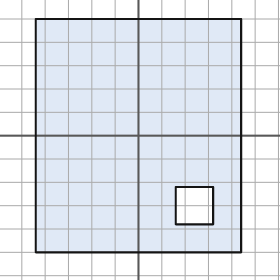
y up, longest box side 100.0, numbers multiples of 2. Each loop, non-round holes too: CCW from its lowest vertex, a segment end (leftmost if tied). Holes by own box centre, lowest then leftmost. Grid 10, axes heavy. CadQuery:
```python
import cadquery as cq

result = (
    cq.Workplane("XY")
    .moveTo(-44.0, -50.0)
    .lineTo(44.0, -50.0)
    .lineTo(44.0, 50.0)
    .lineTo(-44.0, 50.0)
    .close()
    .moveTo(16.0, -38.0)
    .lineTo(32.0, -38.0)
    .lineTo(32.0, -22.0)
    .lineTo(16.0, -22.0)
    .close()
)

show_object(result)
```